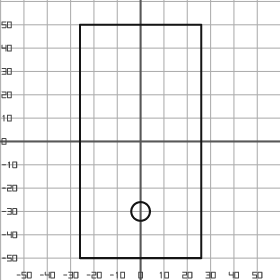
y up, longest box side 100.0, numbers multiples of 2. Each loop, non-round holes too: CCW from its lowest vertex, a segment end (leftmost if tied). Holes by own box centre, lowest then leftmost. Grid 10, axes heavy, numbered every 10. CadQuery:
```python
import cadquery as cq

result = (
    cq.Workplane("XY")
    .moveTo(-26.0, -50.0)
    .lineTo(26.0, -50.0)
    .lineTo(26.0, 50.0)
    .lineTo(-26.0, 50.0)
    .close()
    .moveTo(0.0, -30.0)
    .circle(4.0)
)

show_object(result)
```